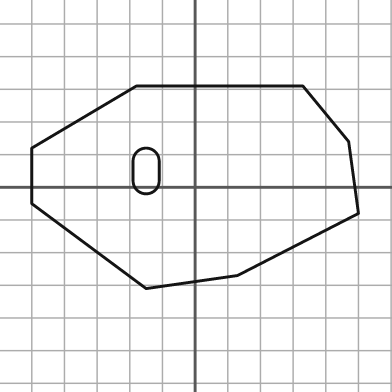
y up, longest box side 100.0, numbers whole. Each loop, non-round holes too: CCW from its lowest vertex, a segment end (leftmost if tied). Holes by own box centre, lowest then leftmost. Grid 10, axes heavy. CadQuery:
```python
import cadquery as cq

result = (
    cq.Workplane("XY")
    .moveTo(-15.0, -31.0)
    .lineTo(13.0, -27.0)
    .lineTo(50.0, -8.0)
    .lineTo(47.0, 14.0)
    .lineTo(33.0, 31.0)
    .lineTo(-18.0, 31.0)
    .lineTo(-50.0, 12.0)
    .lineTo(-50.0, -5.0)
    .close()
    .moveTo(-19.0, 2.0)
    .threePointArc((-15.0, -2.0), (-11.0, 2.0))
    .lineTo(-11.0, 8.0)
    .threePointArc((-15.0, 12.0), (-19.0, 8.0))
    .close()
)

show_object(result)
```